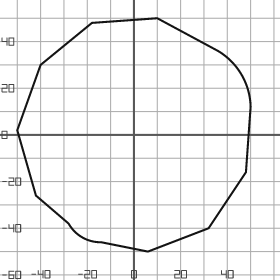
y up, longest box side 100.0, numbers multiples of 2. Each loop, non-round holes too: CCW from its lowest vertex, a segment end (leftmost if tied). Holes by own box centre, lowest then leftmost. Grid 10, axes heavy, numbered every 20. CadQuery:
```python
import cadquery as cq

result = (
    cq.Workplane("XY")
    .moveTo(6.0, -50.0)
    .lineTo(32.0, -40.0)
    .lineTo(48.0, -16.0)
    .lineTo(50.0, 12.0)
    .threePointArc((46.0, 26.0), (36.0, 36.0))
    .lineTo(10.0, 50.0)
    .lineTo(-18.0, 48.0)
    .lineTo(-40.0, 30.0)
    .lineTo(-50.0, 2.0)
    .lineTo(-42.0, -26.0)
    .lineTo(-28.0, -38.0)
    .threePointArc((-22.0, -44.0), (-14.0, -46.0))
    .close()
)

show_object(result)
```